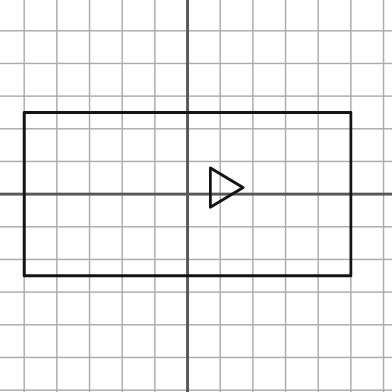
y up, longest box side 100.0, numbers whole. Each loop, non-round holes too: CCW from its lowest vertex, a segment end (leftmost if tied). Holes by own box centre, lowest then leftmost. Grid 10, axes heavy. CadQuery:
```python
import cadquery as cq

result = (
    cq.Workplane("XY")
    .moveTo(-50.0, -25.0)
    .lineTo(50.0, -25.0)
    .lineTo(50.0, 25.0)
    .lineTo(-50.0, 25.0)
    .close()
    .moveTo(7.0, -4.0)
    .lineTo(17.0, 2.0)
    .lineTo(7.0, 8.0)
    .close()
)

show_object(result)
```